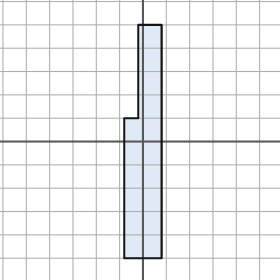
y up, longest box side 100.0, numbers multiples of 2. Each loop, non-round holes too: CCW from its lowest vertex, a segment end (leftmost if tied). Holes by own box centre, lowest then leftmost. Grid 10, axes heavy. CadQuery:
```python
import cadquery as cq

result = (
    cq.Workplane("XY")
    .moveTo(-8.0, -50.0)
    .lineTo(8.0, -50.0)
    .lineTo(8.0, 50.0)
    .lineTo(-2.0, 50.0)
    .lineTo(-2.0, 10.0)
    .lineTo(-8.0, 10.0)
    .close()
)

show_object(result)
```